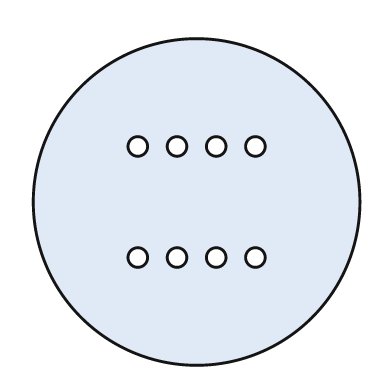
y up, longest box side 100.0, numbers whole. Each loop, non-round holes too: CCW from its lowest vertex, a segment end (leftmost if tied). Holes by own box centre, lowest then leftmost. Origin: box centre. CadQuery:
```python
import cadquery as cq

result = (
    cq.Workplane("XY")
    .moveTo(0.0, 0.0)
    .circle(50.0)
    .moveTo(-18.0, -17.0)
    .circle(3.0)
    .moveTo(-6.0, -17.0)
    .circle(3.0)
    .moveTo(6.0, -17.0)
    .circle(3.0)
    .moveTo(18.0, -17.0)
    .circle(3.0)
    .moveTo(-18.0, 17.0)
    .circle(3.0)
    .moveTo(-6.0, 17.0)
    .circle(3.0)
    .moveTo(6.0, 17.0)
    .circle(3.0)
    .moveTo(18.0, 17.0)
    .circle(3.0)
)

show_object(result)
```